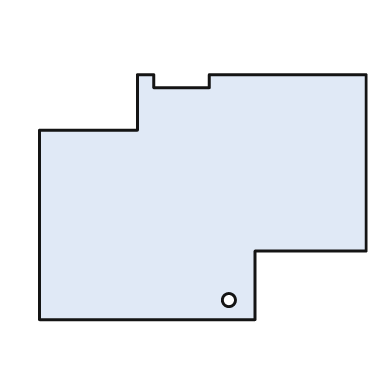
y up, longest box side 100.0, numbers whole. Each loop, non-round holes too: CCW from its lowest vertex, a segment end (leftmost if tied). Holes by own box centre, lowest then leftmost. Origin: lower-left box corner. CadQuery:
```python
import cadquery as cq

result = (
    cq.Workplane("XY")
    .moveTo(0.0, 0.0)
    .lineTo(66.0, 0.0)
    .lineTo(66.0, 21.0)
    .lineTo(100.0, 21.0)
    .lineTo(100.0, 75.0)
    .lineTo(52.0, 75.0)
    .lineTo(52.0, 71.0)
    .lineTo(35.0, 71.0)
    .lineTo(35.0, 75.0)
    .lineTo(30.0, 75.0)
    .lineTo(30.0, 58.0)
    .lineTo(0.0, 58.0)
    .close()
    .moveTo(58.0, 6.0)
    .circle(2.0)
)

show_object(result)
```